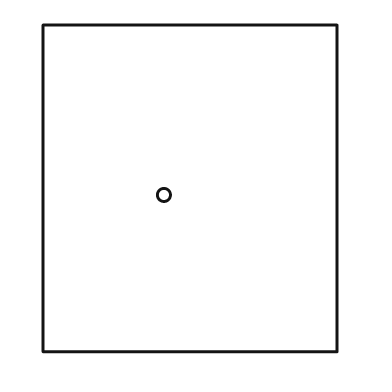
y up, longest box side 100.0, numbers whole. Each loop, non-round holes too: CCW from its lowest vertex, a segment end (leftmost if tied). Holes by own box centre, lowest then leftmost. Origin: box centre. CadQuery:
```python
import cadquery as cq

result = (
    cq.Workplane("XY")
    .moveTo(-45.0, -50.0)
    .lineTo(45.0, -50.0)
    .lineTo(45.0, 50.0)
    .lineTo(-45.0, 50.0)
    .close()
    .moveTo(-8.0, -2.0)
    .circle(2.0)
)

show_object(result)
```